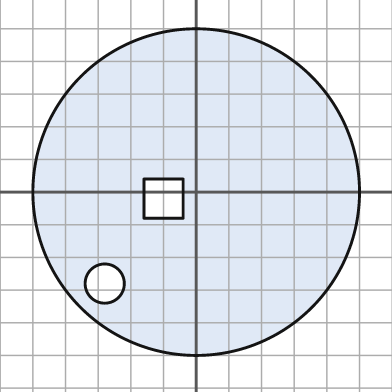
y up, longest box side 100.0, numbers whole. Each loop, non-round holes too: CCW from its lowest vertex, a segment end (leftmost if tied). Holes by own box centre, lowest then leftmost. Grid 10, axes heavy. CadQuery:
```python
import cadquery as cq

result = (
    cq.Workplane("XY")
    .moveTo(0.0, 0.0)
    .circle(50.0)
    .moveTo(-28.0, -28.0)
    .circle(6.0)
    .moveTo(-16.0, -8.0)
    .lineTo(-4.0, -8.0)
    .lineTo(-4.0, 4.0)
    .lineTo(-16.0, 4.0)
    .close()
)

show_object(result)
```